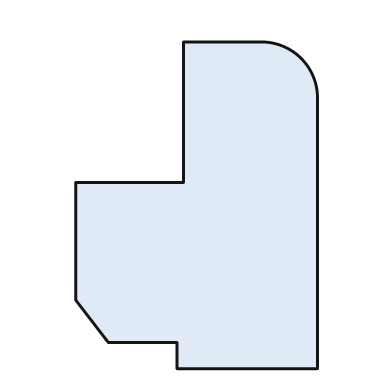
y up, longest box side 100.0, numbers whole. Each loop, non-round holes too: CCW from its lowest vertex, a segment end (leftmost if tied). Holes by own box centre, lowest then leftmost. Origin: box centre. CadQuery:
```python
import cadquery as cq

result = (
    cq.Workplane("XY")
    .moveTo(-6.0, -50.0)
    .lineTo(37.0, -50.0)
    .lineTo(37.0, 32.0)
    .threePointArc((32.0, 45.0), (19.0, 50.0))
    .lineTo(-4.0, 50.0)
    .lineTo(-4.0, 7.0)
    .lineTo(-37.0, 7.0)
    .lineTo(-37.0, -29.0)
    .lineTo(-27.0, -42.0)
    .lineTo(-6.0, -42.0)
    .close()
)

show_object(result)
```